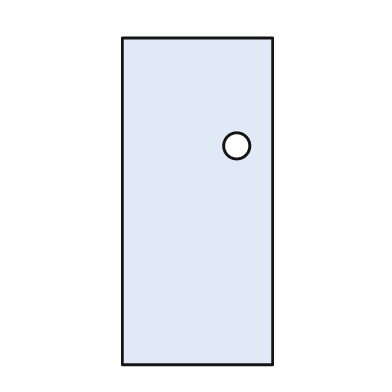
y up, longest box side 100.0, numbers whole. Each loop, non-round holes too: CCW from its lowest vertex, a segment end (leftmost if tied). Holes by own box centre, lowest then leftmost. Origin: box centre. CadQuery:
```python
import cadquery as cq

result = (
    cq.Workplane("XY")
    .moveTo(-23.0, -50.0)
    .lineTo(23.0, -50.0)
    .lineTo(23.0, 50.0)
    .lineTo(-23.0, 50.0)
    .close()
    .moveTo(12.0, 17.0)
    .circle(4.0)
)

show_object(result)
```